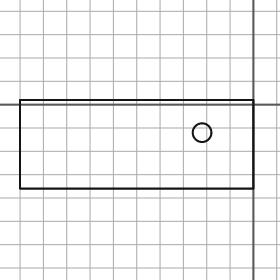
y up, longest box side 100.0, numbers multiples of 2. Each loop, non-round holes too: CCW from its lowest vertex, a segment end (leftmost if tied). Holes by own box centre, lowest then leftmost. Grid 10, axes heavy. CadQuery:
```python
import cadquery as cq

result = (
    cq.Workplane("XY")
    .moveTo(-100.0, -36.0)
    .lineTo(0.0, -36.0)
    .lineTo(0.0, 2.0)
    .lineTo(-100.0, 2.0)
    .close()
    .moveTo(-22.0, -12.0)
    .circle(4.0)
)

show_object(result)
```